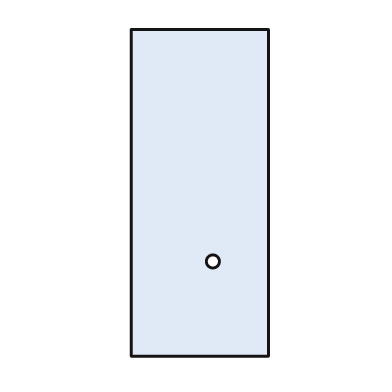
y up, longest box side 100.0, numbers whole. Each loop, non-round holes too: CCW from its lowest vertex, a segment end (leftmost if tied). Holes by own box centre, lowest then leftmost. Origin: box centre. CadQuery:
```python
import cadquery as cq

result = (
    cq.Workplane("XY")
    .moveTo(-21.0, -50.0)
    .lineTo(21.0, -50.0)
    .lineTo(21.0, 50.0)
    .lineTo(-21.0, 50.0)
    .close()
    .moveTo(4.0, -21.0)
    .circle(2.0)
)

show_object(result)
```